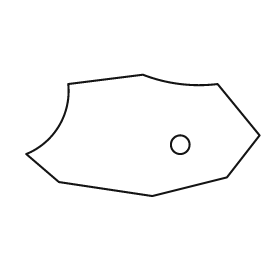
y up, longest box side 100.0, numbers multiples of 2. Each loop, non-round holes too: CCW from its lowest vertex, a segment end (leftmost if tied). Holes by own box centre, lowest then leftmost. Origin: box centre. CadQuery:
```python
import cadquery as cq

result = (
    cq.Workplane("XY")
    .moveTo(4.0, -26.0)
    .lineTo(36.0, -18.0)
    .lineTo(50.0, 0.0)
    .lineTo(32.0, 22.0)
    .threePointArc((16.0, 22.0), (0.0, 26.0))
    .lineTo(-32.0, 22.0)
    .threePointArc((-36.0, 4.0), (-50.0, -8.0))
    .lineTo(-36.0, -20.0)
    .close()
    .moveTo(16.0, -4.0)
    .circle(4.0)
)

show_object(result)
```